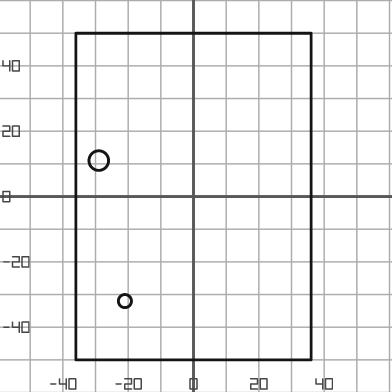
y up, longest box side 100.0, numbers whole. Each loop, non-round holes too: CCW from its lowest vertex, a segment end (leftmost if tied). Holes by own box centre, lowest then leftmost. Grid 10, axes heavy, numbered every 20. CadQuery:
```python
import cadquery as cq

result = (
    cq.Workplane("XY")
    .moveTo(-36.0, -50.0)
    .lineTo(36.0, -50.0)
    .lineTo(36.0, 50.0)
    .lineTo(-36.0, 50.0)
    .close()
    .moveTo(-21.0, -32.0)
    .circle(2.0)
    .moveTo(-29.0, 11.0)
    .circle(3.0)
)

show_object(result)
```